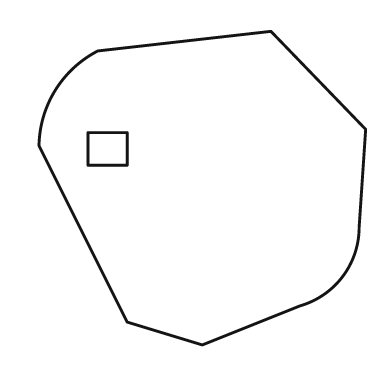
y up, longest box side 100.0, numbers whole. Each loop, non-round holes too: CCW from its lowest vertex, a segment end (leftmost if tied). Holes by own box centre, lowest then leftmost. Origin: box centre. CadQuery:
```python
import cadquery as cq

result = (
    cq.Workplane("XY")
    .moveTo(0.0, -48.0)
    .lineTo(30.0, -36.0)
    .threePointArc((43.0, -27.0), (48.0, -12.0))
    .lineTo(50.0, 18.0)
    .lineTo(21.0, 48.0)
    .lineTo(-32.0, 42.0)
    .threePointArc((-45.0, 30.0), (-50.0, 13.0))
    .lineTo(-23.0, -41.0)
    .close()
    .moveTo(-35.0, 7.0)
    .lineTo(-23.0, 7.0)
    .lineTo(-23.0, 17.0)
    .lineTo(-35.0, 17.0)
    .close()
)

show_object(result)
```